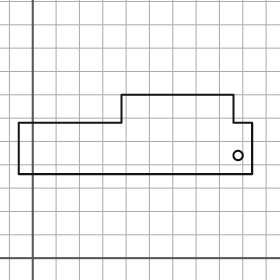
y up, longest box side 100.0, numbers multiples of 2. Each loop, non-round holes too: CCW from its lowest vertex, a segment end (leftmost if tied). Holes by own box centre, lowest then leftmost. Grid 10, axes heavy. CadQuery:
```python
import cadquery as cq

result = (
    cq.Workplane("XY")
    .moveTo(-6.0, 36.0)
    .lineTo(94.0, 36.0)
    .lineTo(94.0, 58.0)
    .lineTo(86.0, 58.0)
    .lineTo(86.0, 70.0)
    .lineTo(38.0, 70.0)
    .lineTo(38.0, 58.0)
    .lineTo(-6.0, 58.0)
    .close()
    .moveTo(88.0, 44.0)
    .circle(2.0)
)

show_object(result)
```